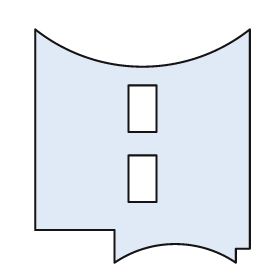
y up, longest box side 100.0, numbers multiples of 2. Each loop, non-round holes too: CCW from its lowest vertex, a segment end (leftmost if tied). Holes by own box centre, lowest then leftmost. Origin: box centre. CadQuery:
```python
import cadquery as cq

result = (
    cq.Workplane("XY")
    .moveTo(-12.0, -50.0)
    .threePointArc((14.0, -42.0), (40.0, -50.0))
    .lineTo(40.0, -44.0)
    .lineTo(46.0, -44.0)
    .lineTo(46.0, 50.0)
    .threePointArc((0.0, 34.0), (-46.0, 50.0))
    .lineTo(-46.0, -36.0)
    .lineTo(-12.0, -36.0)
    .close()
    .moveTo(-6.0, -24.0)
    .lineTo(6.0, -24.0)
    .lineTo(6.0, -4.0)
    .lineTo(-6.0, -4.0)
    .close()
    .moveTo(-6.0, 6.0)
    .lineTo(6.0, 6.0)
    .lineTo(6.0, 26.0)
    .lineTo(-6.0, 26.0)
    .close()
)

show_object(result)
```